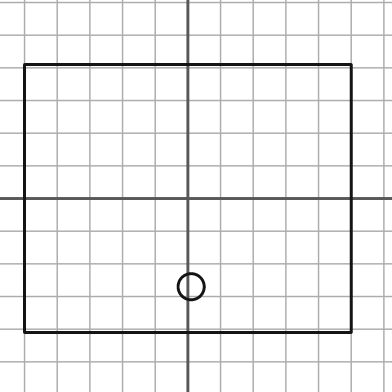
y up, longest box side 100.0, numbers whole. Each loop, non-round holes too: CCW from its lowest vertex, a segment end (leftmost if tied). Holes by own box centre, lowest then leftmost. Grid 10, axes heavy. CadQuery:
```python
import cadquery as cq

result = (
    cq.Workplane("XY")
    .moveTo(-50.0, -41.0)
    .lineTo(50.0, -41.0)
    .lineTo(50.0, 41.0)
    .lineTo(-50.0, 41.0)
    .close()
    .moveTo(1.0, -27.0)
    .circle(4.0)
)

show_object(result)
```